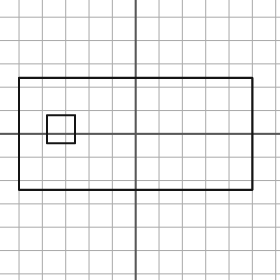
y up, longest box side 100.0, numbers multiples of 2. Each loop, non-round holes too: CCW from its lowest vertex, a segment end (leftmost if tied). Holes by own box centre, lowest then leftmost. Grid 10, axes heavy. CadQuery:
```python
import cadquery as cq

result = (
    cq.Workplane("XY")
    .moveTo(-50.0, -24.0)
    .lineTo(50.0, -24.0)
    .lineTo(50.0, 24.0)
    .lineTo(-50.0, 24.0)
    .close()
    .moveTo(-38.0, -4.0)
    .lineTo(-26.0, -4.0)
    .lineTo(-26.0, 8.0)
    .lineTo(-38.0, 8.0)
    .close()
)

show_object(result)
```